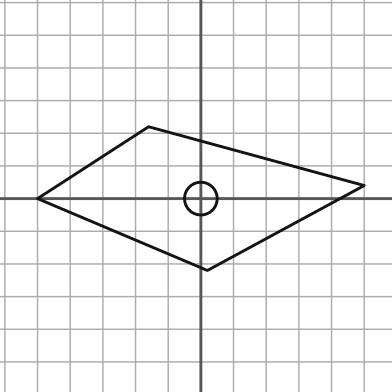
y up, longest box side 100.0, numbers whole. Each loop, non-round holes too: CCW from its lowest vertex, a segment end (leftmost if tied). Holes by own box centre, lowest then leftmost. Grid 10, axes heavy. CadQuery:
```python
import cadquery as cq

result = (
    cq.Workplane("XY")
    .moveTo(2.0, -22.0)
    .lineTo(50.0, 4.0)
    .lineTo(-16.0, 22.0)
    .lineTo(-50.0, 0.0)
    .close()
    .moveTo(0.0, 0.0)
    .circle(5.0)
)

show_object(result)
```